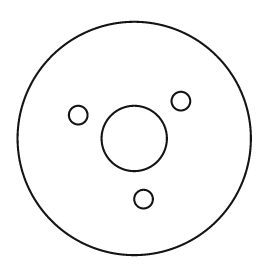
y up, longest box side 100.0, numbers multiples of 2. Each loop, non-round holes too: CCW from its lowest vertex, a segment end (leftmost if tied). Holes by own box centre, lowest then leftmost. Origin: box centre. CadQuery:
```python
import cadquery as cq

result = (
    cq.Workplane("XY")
    .moveTo(0.0, 0.0)
    .circle(50.0)
    .moveTo(4.0, -26.0)
    .circle(4.0)
    .moveTo(0.0, 0.0)
    .circle(14.0)
    .moveTo(-24.0, 10.0)
    .circle(4.0)
    .moveTo(20.0, 16.0)
    .circle(4.0)
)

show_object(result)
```